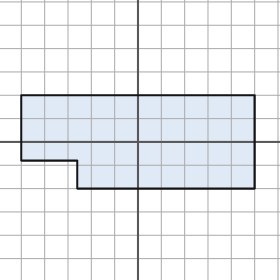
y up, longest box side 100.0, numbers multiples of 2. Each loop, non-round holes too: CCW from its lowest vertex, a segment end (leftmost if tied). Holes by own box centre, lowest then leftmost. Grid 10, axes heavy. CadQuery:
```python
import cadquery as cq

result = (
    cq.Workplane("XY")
    .moveTo(-26.0, -20.0)
    .lineTo(50.0, -20.0)
    .lineTo(50.0, 20.0)
    .lineTo(-50.0, 20.0)
    .lineTo(-50.0, -8.0)
    .lineTo(-26.0, -8.0)
    .close()
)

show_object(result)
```